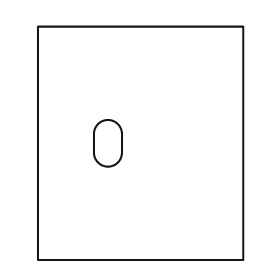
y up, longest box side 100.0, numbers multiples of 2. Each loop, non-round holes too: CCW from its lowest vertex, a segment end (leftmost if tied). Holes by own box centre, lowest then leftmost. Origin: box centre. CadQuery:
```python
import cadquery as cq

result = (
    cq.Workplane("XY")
    .moveTo(-44.0, -50.0)
    .lineTo(44.0, -50.0)
    .lineTo(44.0, 50.0)
    .lineTo(-44.0, 50.0)
    .close()
    .moveTo(-20.0, -4.0)
    .threePointArc((-14.0, -10.0), (-8.0, -4.0))
    .lineTo(-8.0, 4.0)
    .threePointArc((-14.0, 10.0), (-20.0, 4.0))
    .close()
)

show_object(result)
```